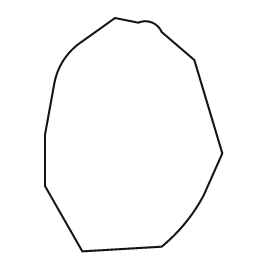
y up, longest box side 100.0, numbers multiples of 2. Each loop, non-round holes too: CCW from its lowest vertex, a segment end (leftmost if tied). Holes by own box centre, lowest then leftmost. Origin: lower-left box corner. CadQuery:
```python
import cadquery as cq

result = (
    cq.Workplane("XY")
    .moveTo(16.0, 0.0)
    .lineTo(50.0, 2.0)
    .threePointArc((60.0, 12.0), (68.0, 24.0))
    .lineTo(76.0, 42.0)
    .lineTo(64.0, 82.0)
    .lineTo(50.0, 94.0)
    .threePointArc((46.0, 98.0), (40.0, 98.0))
    .lineTo(30.0, 100.0)
    .lineTo(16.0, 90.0)
    .threePointArc((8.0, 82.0), (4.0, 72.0))
    .lineTo(0.0, 50.0)
    .lineTo(0.0, 28.0)
    .close()
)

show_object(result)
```